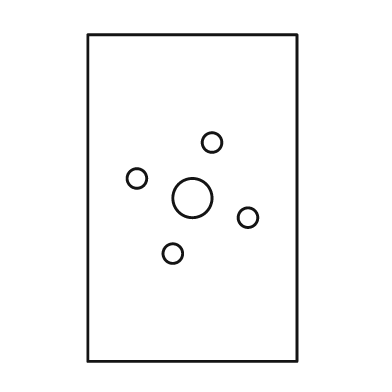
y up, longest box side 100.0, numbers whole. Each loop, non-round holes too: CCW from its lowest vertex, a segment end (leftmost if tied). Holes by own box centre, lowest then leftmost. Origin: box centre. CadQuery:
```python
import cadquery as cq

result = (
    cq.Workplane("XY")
    .moveTo(-32.0, -50.0)
    .lineTo(32.0, -50.0)
    .lineTo(32.0, 50.0)
    .lineTo(-32.0, 50.0)
    .close()
    .moveTo(-6.0, -17.0)
    .circle(3.0)
    .moveTo(17.0, -6.0)
    .circle(3.0)
    .moveTo(0.0, 0.0)
    .circle(6.0)
    .moveTo(-17.0, 6.0)
    .circle(3.0)
    .moveTo(6.0, 17.0)
    .circle(3.0)
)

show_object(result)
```